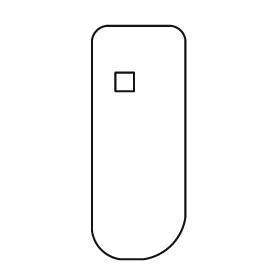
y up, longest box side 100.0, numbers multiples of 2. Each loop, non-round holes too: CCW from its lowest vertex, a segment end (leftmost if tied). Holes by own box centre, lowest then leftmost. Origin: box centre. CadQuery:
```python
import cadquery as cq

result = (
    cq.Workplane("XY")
    .moveTo(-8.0, -50.0)
    .lineTo(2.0, -50.0)
    .threePointArc((14.0, -44.0), (20.0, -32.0))
    .lineTo(20.0, 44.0)
    .threePointArc((18.0, 48.0), (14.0, 50.0))
    .lineTo(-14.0, 50.0)
    .threePointArc((-18.0, 48.0), (-20.0, 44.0))
    .lineTo(-20.0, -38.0)
    .threePointArc((-16.0, -46.0), (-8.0, -50.0))
    .close()
    .moveTo(-10.0, 22.0)
    .lineTo(-2.0, 22.0)
    .lineTo(-2.0, 30.0)
    .lineTo(-10.0, 30.0)
    .close()
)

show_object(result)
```